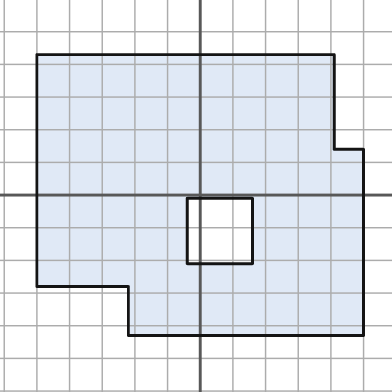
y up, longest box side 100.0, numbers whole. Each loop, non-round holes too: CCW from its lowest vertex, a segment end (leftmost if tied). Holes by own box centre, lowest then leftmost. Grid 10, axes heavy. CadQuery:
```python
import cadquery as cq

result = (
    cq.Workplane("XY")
    .moveTo(-22.0, -43.0)
    .lineTo(50.0, -43.0)
    .lineTo(50.0, 14.0)
    .lineTo(41.0, 14.0)
    .lineTo(41.0, 43.0)
    .lineTo(-50.0, 43.0)
    .lineTo(-50.0, -28.0)
    .lineTo(-22.0, -28.0)
    .close()
    .moveTo(-4.0, -21.0)
    .lineTo(16.0, -21.0)
    .lineTo(16.0, -1.0)
    .lineTo(-4.0, -1.0)
    .close()
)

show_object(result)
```